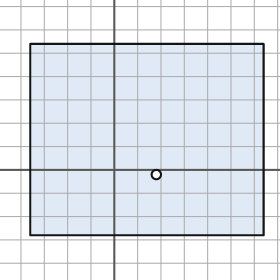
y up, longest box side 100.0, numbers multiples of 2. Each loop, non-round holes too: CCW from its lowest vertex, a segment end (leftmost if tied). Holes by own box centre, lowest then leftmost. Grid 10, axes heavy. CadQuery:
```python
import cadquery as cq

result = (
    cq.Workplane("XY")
    .moveTo(-36.0, -28.0)
    .lineTo(64.0, -28.0)
    .lineTo(64.0, 54.0)
    .lineTo(-36.0, 54.0)
    .close()
    .moveTo(18.0, -2.0)
    .circle(2.0)
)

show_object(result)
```